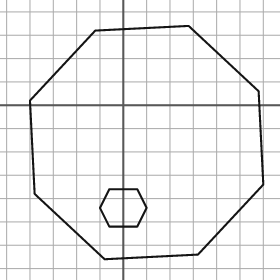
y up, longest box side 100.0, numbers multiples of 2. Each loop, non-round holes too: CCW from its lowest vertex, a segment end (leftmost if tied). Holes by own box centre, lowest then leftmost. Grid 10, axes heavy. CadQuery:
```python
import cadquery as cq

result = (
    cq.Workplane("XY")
    .moveTo(-8.0, -66.0)
    .lineTo(32.0, -64.0)
    .lineTo(60.0, -34.0)
    .lineTo(58.0, 6.0)
    .lineTo(28.0, 34.0)
    .lineTo(-12.0, 32.0)
    .lineTo(-40.0, 2.0)
    .lineTo(-38.0, -38.0)
    .close()
    .moveTo(-6.0, -52.0)
    .lineTo(6.0, -52.0)
    .lineTo(10.0, -44.0)
    .lineTo(6.0, -36.0)
    .lineTo(-6.0, -36.0)
    .lineTo(-10.0, -44.0)
    .close()
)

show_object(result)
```